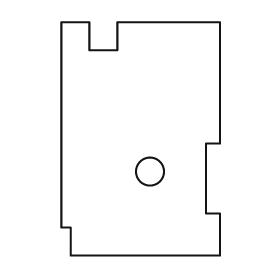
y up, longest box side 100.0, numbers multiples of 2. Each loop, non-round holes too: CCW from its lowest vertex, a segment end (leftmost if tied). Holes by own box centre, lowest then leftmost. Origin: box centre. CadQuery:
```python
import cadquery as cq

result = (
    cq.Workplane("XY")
    .moveTo(-30.0, -50.0)
    .lineTo(34.0, -50.0)
    .lineTo(34.0, -32.0)
    .lineTo(28.0, -32.0)
    .lineTo(28.0, -2.0)
    .lineTo(34.0, -2.0)
    .lineTo(34.0, 50.0)
    .lineTo(-10.0, 50.0)
    .lineTo(-10.0, 38.0)
    .lineTo(-22.0, 38.0)
    .lineTo(-22.0, 50.0)
    .lineTo(-34.0, 50.0)
    .lineTo(-34.0, -38.0)
    .lineTo(-30.0, -38.0)
    .close()
    .moveTo(4.0, -14.0)
    .circle(6.0)
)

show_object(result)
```